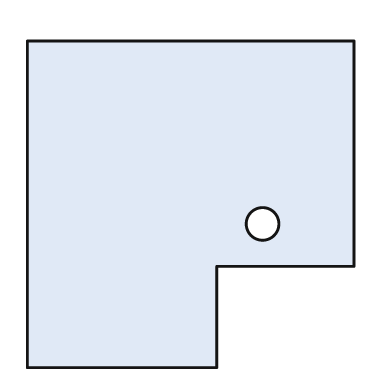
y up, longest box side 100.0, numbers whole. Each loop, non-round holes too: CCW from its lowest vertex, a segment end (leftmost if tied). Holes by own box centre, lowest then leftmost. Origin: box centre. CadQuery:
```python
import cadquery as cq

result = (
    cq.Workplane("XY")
    .moveTo(-50.0, -50.0)
    .lineTo(8.0, -50.0)
    .lineTo(8.0, -19.0)
    .lineTo(50.0, -19.0)
    .lineTo(50.0, 50.0)
    .lineTo(-50.0, 50.0)
    .close()
    .moveTo(22.0, -6.0)
    .circle(5.0)
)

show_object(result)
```